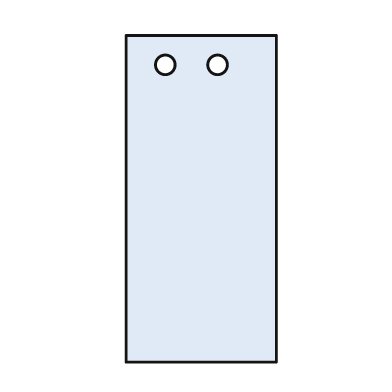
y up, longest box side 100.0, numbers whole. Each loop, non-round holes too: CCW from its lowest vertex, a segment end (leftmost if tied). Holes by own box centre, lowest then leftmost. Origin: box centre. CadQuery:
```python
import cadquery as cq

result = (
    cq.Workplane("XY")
    .moveTo(-23.0, -50.0)
    .lineTo(23.0, -50.0)
    .lineTo(23.0, 50.0)
    .lineTo(-23.0, 50.0)
    .close()
    .moveTo(-11.0, 41.0)
    .circle(3.0)
    .moveTo(5.0, 41.0)
    .circle(3.0)
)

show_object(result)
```